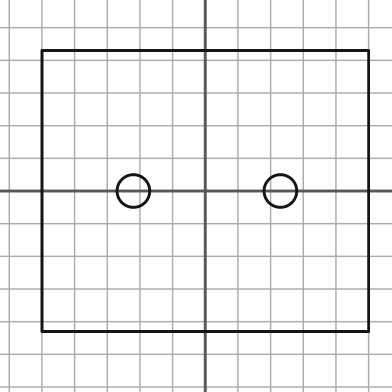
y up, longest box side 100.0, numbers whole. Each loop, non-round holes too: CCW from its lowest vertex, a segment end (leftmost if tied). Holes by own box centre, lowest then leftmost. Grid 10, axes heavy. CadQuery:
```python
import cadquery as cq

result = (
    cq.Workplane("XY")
    .moveTo(-50.0, -43.0)
    .lineTo(50.0, -43.0)
    .lineTo(50.0, 43.0)
    .lineTo(-50.0, 43.0)
    .close()
    .moveTo(-22.0, 0.0)
    .circle(5.0)
    .moveTo(23.0, 0.0)
    .circle(5.0)
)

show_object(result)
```